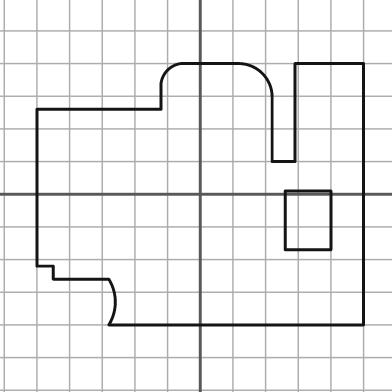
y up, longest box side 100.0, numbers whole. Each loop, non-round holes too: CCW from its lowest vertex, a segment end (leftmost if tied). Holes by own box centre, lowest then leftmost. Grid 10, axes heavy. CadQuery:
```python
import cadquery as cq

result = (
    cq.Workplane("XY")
    .moveTo(-28.0, -40.0)
    .lineTo(50.0, -40.0)
    .lineTo(50.0, 40.0)
    .lineTo(29.0, 40.0)
    .lineTo(29.0, 10.0)
    .lineTo(22.0, 10.0)
    .lineTo(22.0, 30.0)
    .threePointArc((19.0, 37.0), (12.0, 40.0))
    .lineTo(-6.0, 40.0)
    .threePointArc((-10.0, 38.0), (-12.0, 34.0))
    .lineTo(-12.0, 26.0)
    .lineTo(-50.0, 26.0)
    .lineTo(-50.0, -22.0)
    .lineTo(-45.0, -22.0)
    .lineTo(-45.0, -26.0)
    .lineTo(-28.0, -26.0)
    .threePointArc((-26.0, -33.0), (-28.0, -40.0))
    .close()
    .moveTo(26.0, -17.0)
    .lineTo(40.0, -17.0)
    .lineTo(40.0, 1.0)
    .lineTo(26.0, 1.0)
    .close()
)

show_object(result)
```